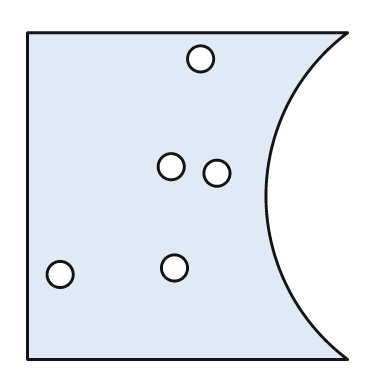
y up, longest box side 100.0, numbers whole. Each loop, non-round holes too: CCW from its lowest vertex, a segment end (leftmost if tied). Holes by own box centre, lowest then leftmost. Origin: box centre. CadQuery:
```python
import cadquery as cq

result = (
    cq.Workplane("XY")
    .moveTo(-49.0, -50.0)
    .lineTo(49.0, -50.0)
    .threePointArc((24.0, 0.0), (49.0, 50.0))
    .lineTo(-49.0, 50.0)
    .close()
    .moveTo(-39.0, -24.0)
    .circle(4.0)
    .moveTo(-4.0, -22.0)
    .circle(4.0)
    .moveTo(9.0, 7.0)
    .circle(4.0)
    .moveTo(-5.0, 9.0)
    .circle(4.0)
    .moveTo(4.0, 42.0)
    .circle(4.0)
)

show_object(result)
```